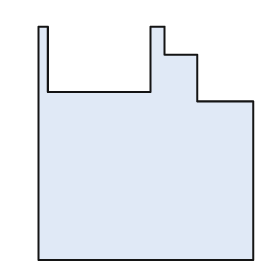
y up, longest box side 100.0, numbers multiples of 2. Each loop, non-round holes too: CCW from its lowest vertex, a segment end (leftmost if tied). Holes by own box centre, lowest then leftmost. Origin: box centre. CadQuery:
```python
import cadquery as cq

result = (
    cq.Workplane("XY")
    .moveTo(-46.0, -50.0)
    .lineTo(46.0, -50.0)
    .lineTo(46.0, 18.0)
    .lineTo(22.0, 18.0)
    .lineTo(22.0, 38.0)
    .lineTo(8.0, 38.0)
    .lineTo(8.0, 50.0)
    .lineTo(2.0, 50.0)
    .lineTo(2.0, 22.0)
    .lineTo(-42.0, 22.0)
    .lineTo(-42.0, 50.0)
    .lineTo(-46.0, 50.0)
    .close()
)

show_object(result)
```